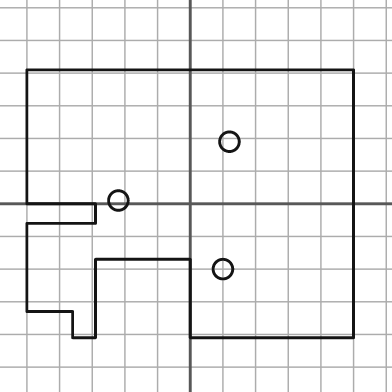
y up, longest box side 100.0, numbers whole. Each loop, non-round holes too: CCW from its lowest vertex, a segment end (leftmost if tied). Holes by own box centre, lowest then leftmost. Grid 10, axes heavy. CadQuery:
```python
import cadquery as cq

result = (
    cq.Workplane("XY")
    .moveTo(-36.0, -41.0)
    .lineTo(-29.0, -41.0)
    .lineTo(-29.0, -17.0)
    .lineTo(0.0, -17.0)
    .lineTo(0.0, -41.0)
    .lineTo(50.0, -41.0)
    .lineTo(50.0, 41.0)
    .lineTo(-50.0, 41.0)
    .lineTo(-50.0, 0.0)
    .lineTo(-29.0, 0.0)
    .lineTo(-29.0, -6.0)
    .lineTo(-50.0, -6.0)
    .lineTo(-50.0, -33.0)
    .lineTo(-36.0, -33.0)
    .close()
    .moveTo(10.0, -20.0)
    .circle(3.0)
    .moveTo(-22.0, 1.0)
    .circle(3.0)
    .moveTo(12.0, 19.0)
    .circle(3.0)
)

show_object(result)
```